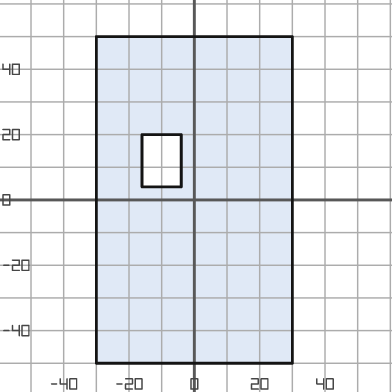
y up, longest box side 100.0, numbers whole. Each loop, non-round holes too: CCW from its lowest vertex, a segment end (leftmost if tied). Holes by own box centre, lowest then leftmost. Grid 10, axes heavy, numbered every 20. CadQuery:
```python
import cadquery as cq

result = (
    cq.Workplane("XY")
    .moveTo(-30.0, -50.0)
    .lineTo(30.0, -50.0)
    .lineTo(30.0, 50.0)
    .lineTo(-30.0, 50.0)
    .close()
    .moveTo(-16.0, 4.0)
    .lineTo(-4.0, 4.0)
    .lineTo(-4.0, 20.0)
    .lineTo(-16.0, 20.0)
    .close()
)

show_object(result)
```